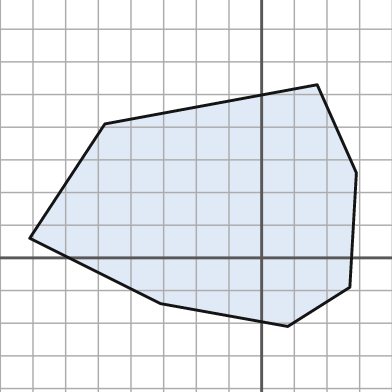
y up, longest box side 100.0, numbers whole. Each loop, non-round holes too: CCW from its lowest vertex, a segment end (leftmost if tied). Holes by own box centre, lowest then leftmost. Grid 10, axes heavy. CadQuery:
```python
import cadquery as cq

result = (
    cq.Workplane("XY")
    .moveTo(8.0, -21.0)
    .lineTo(27.0, -9.0)
    .lineTo(29.0, 26.0)
    .lineTo(17.0, 53.0)
    .lineTo(-48.0, 41.0)
    .lineTo(-71.0, 6.0)
    .lineTo(-31.0, -14.0)
    .close()
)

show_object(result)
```